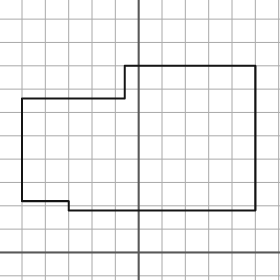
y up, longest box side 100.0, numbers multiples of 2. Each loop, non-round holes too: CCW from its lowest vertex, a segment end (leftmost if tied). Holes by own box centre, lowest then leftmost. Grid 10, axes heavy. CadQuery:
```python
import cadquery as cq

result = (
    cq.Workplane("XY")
    .moveTo(-30.0, 18.0)
    .lineTo(50.0, 18.0)
    .lineTo(50.0, 80.0)
    .lineTo(-6.0, 80.0)
    .lineTo(-6.0, 66.0)
    .lineTo(-50.0, 66.0)
    .lineTo(-50.0, 22.0)
    .lineTo(-30.0, 22.0)
    .close()
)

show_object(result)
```